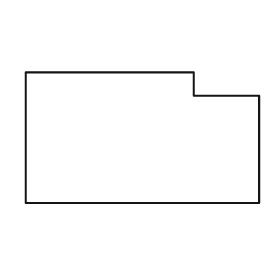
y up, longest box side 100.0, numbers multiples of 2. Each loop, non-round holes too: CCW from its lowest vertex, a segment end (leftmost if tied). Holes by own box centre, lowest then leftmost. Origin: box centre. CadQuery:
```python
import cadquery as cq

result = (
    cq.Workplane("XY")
    .moveTo(-50.0, -28.0)
    .lineTo(50.0, -28.0)
    .lineTo(50.0, 18.0)
    .lineTo(22.0, 18.0)
    .lineTo(22.0, 28.0)
    .lineTo(-50.0, 28.0)
    .close()
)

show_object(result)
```